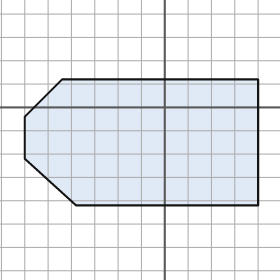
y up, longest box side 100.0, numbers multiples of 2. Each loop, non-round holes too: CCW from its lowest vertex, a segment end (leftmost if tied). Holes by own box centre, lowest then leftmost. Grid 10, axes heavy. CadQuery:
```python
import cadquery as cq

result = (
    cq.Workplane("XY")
    .moveTo(-38.0, -42.0)
    .lineTo(40.0, -42.0)
    .lineTo(40.0, 12.0)
    .lineTo(-44.0, 12.0)
    .lineTo(-60.0, -4.0)
    .lineTo(-60.0, -22.0)
    .close()
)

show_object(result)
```